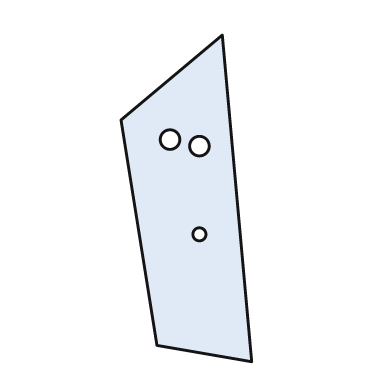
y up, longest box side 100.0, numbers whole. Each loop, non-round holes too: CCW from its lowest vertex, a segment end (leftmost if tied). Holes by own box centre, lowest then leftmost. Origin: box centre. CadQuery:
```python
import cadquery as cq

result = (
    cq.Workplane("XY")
    .moveTo(20.0, -50.0)
    .lineTo(11.0, 50.0)
    .lineTo(-20.0, 24.0)
    .lineTo(-9.0, -45.0)
    .close()
    .moveTo(4.0, -11.0)
    .circle(2.0)
    .moveTo(4.0, 16.0)
    .circle(3.0)
    .moveTo(-5.0, 18.0)
    .circle(3.0)
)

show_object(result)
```